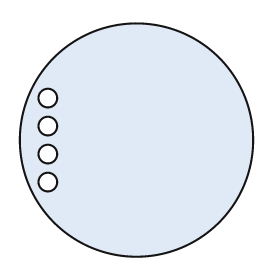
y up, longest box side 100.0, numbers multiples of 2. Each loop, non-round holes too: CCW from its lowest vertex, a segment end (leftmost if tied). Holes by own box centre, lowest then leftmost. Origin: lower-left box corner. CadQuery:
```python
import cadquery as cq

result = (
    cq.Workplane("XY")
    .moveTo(50.0, 50.0)
    .circle(50.0)
    .moveTo(12.0, 32.0)
    .circle(4.0)
    .moveTo(12.0, 44.0)
    .circle(4.0)
    .moveTo(12.0, 56.0)
    .circle(4.0)
    .moveTo(12.0, 68.0)
    .circle(4.0)
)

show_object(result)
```